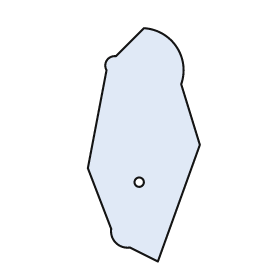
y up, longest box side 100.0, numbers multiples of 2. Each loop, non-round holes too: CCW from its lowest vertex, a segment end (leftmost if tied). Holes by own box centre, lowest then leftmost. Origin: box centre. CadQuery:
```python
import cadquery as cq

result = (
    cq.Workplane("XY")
    .moveTo(6.0, -50.0)
    .lineTo(24.0, 0.0)
    .lineTo(16.0, 26.0)
    .threePointArc((14.0, 42.0), (0.0, 50.0))
    .lineTo(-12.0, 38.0)
    .threePointArc((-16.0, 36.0), (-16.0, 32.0))
    .lineTo(-24.0, -10.0)
    .lineTo(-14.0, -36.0)
    .threePointArc((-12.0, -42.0), (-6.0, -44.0))
    .close()
    .moveTo(-2.0, -16.0)
    .circle(2.0)
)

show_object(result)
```